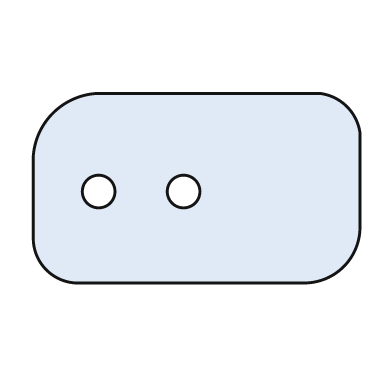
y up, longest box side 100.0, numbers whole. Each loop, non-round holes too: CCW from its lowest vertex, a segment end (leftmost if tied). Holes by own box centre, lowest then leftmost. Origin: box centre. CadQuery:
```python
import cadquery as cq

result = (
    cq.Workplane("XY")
    .moveTo(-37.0, -29.0)
    .lineTo(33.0, -29.0)
    .threePointArc((45.0, -24.0), (50.0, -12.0))
    .lineTo(50.0, 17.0)
    .threePointArc((46.0, 25.0), (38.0, 29.0))
    .lineTo(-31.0, 29.0)
    .threePointArc((-44.0, 23.0), (-50.0, 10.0))
    .lineTo(-50.0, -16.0)
    .threePointArc((-46.0, -25.0), (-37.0, -29.0))
    .close()
    .moveTo(-30.0, -1.0)
    .circle(5.0)
    .moveTo(-4.0, -1.0)
    .circle(5.0)
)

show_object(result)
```